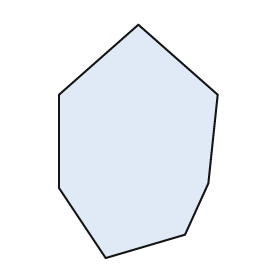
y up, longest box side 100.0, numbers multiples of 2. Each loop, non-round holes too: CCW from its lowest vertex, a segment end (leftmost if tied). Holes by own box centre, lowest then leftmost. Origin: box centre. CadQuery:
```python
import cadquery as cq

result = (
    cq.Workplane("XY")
    .moveTo(-14.0, -50.0)
    .lineTo(20.0, -40.0)
    .lineTo(30.0, -18.0)
    .lineTo(34.0, 20.0)
    .lineTo(0.0, 50.0)
    .lineTo(-34.0, 20.0)
    .lineTo(-34.0, -20.0)
    .close()
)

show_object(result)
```